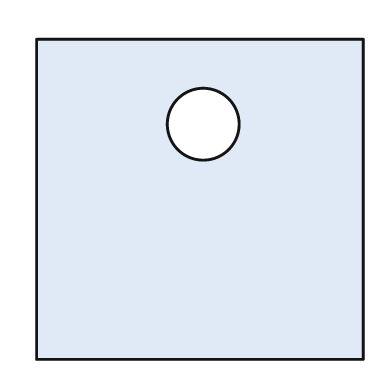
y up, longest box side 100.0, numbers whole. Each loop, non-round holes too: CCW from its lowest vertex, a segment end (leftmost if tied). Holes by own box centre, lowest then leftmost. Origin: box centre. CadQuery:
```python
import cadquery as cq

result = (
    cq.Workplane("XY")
    .moveTo(-50.0, -49.0)
    .lineTo(50.0, -49.0)
    .lineTo(50.0, 49.0)
    .lineTo(-50.0, 49.0)
    .close()
    .moveTo(1.0, 23.0)
    .circle(11.0)
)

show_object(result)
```